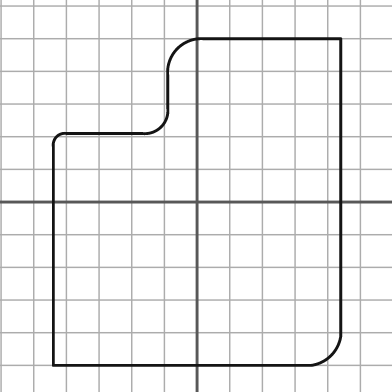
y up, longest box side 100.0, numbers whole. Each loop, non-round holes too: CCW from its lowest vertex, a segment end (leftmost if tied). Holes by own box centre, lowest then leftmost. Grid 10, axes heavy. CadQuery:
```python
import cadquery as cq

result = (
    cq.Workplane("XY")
    .moveTo(-44.0, -50.0)
    .lineTo(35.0, -50.0)
    .threePointArc((41.0, -47.0), (44.0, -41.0))
    .lineTo(44.0, 50.0)
    .lineTo(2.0, 50.0)
    .threePointArc((-6.0, 47.0), (-9.0, 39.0))
    .lineTo(-9.0, 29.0)
    .threePointArc((-11.0, 23.0), (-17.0, 21.0))
    .lineTo(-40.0, 21.0)
    .threePointArc((-43.0, 20.0), (-44.0, 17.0))
    .close()
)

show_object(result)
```